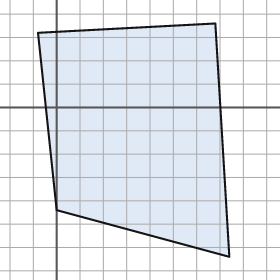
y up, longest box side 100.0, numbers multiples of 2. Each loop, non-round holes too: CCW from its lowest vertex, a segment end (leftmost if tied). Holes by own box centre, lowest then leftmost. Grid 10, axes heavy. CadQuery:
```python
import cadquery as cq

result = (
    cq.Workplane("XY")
    .moveTo(74.0, -64.0)
    .lineTo(68.0, 36.0)
    .lineTo(-8.0, 32.0)
    .lineTo(0.0, -44.0)
    .close()
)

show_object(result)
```